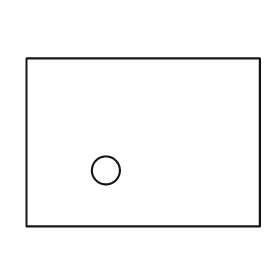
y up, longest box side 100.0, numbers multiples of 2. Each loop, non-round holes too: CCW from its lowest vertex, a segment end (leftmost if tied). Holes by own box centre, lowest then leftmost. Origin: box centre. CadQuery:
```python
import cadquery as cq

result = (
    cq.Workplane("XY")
    .moveTo(-50.0, -36.0)
    .lineTo(50.0, -36.0)
    .lineTo(50.0, 36.0)
    .lineTo(-50.0, 36.0)
    .close()
    .moveTo(-16.0, -12.0)
    .circle(6.0)
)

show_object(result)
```